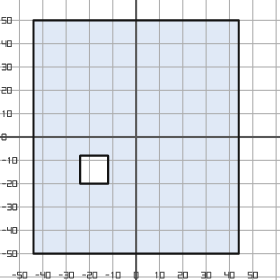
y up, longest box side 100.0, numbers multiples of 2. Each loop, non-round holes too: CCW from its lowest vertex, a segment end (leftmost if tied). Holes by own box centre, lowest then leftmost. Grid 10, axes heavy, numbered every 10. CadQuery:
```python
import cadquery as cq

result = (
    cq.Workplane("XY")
    .moveTo(-44.0, -50.0)
    .lineTo(44.0, -50.0)
    .lineTo(44.0, 50.0)
    .lineTo(-44.0, 50.0)
    .close()
    .moveTo(-24.0, -20.0)
    .lineTo(-12.0, -20.0)
    .lineTo(-12.0, -8.0)
    .lineTo(-24.0, -8.0)
    .close()
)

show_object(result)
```